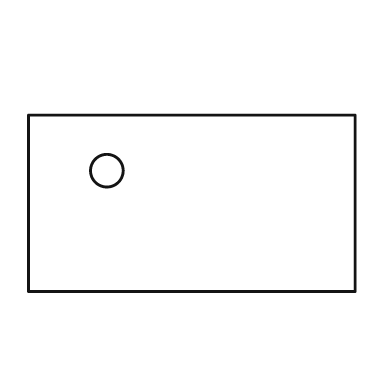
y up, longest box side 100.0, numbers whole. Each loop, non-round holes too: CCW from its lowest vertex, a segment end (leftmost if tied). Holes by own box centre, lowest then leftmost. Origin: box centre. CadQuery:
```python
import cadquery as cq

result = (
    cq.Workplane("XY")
    .moveTo(-50.0, -27.0)
    .lineTo(50.0, -27.0)
    .lineTo(50.0, 27.0)
    .lineTo(-50.0, 27.0)
    .close()
    .moveTo(-26.0, 10.0)
    .circle(5.0)
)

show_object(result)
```